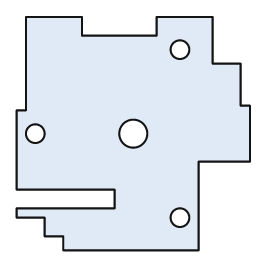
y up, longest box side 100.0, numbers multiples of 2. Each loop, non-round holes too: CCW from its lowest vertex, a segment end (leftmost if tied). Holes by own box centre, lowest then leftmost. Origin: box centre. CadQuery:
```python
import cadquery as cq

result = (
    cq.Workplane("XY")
    .moveTo(-30.0, -50.0)
    .lineTo(28.0, -50.0)
    .lineTo(28.0, -12.0)
    .lineTo(50.0, -12.0)
    .lineTo(50.0, 12.0)
    .lineTo(46.0, 12.0)
    .lineTo(46.0, 30.0)
    .lineTo(34.0, 30.0)
    .lineTo(34.0, 50.0)
    .lineTo(10.0, 50.0)
    .lineTo(10.0, 42.0)
    .lineTo(-22.0, 42.0)
    .lineTo(-22.0, 50.0)
    .lineTo(-46.0, 50.0)
    .lineTo(-46.0, 10.0)
    .lineTo(-50.0, 10.0)
    .lineTo(-50.0, -24.0)
    .lineTo(-8.0, -24.0)
    .lineTo(-8.0, -32.0)
    .lineTo(-50.0, -32.0)
    .lineTo(-50.0, -36.0)
    .lineTo(-38.0, -36.0)
    .lineTo(-38.0, -44.0)
    .lineTo(-30.0, -44.0)
    .close()
    .moveTo(20.0, -36.0)
    .circle(4.0)
    .moveTo(-42.0, 0.0)
    .circle(4.0)
    .moveTo(0.0, 0.0)
    .circle(6.0)
    .moveTo(20.0, 36.0)
    .circle(4.0)
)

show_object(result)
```